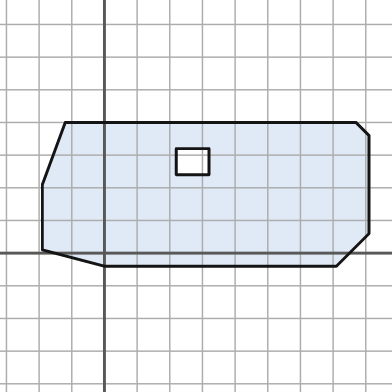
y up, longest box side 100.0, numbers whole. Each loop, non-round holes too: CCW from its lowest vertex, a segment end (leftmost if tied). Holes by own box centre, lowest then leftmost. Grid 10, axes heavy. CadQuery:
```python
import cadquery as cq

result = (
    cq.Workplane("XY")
    .moveTo(0.0, -4.0)
    .lineTo(71.0, -4.0)
    .lineTo(81.0, 6.0)
    .lineTo(81.0, 36.0)
    .lineTo(77.0, 40.0)
    .lineTo(-12.0, 40.0)
    .lineTo(-19.0, 21.0)
    .lineTo(-19.0, 1.0)
    .close()
    .moveTo(22.0, 24.0)
    .lineTo(32.0, 24.0)
    .lineTo(32.0, 32.0)
    .lineTo(22.0, 32.0)
    .close()
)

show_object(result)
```